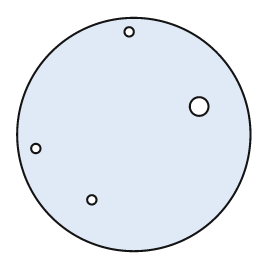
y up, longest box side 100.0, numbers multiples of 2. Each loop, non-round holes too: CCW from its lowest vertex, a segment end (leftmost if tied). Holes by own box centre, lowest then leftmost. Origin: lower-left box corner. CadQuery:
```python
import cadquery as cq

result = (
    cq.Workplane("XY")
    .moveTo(50.0, 50.0)
    .circle(50.0)
    .moveTo(32.0, 22.0)
    .circle(2.0)
    .moveTo(8.0, 44.0)
    .circle(2.0)
    .moveTo(78.0, 62.0)
    .circle(4.0)
    .moveTo(48.0, 94.0)
    .circle(2.0)
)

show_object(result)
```